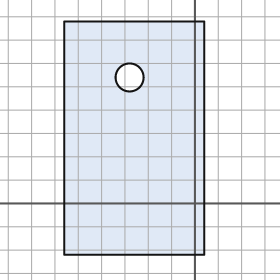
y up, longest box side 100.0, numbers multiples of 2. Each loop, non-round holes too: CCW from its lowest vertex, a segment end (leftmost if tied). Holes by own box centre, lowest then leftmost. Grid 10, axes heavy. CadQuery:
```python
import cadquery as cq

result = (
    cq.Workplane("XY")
    .moveTo(-56.0, -22.0)
    .lineTo(4.0, -22.0)
    .lineTo(4.0, 78.0)
    .lineTo(-56.0, 78.0)
    .close()
    .moveTo(-28.0, 54.0)
    .circle(6.0)
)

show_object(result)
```